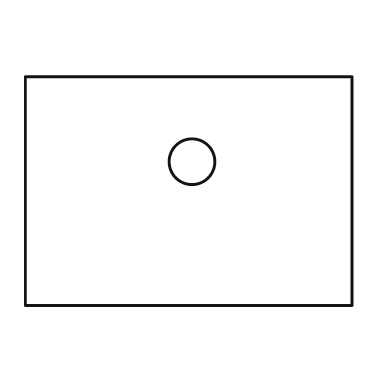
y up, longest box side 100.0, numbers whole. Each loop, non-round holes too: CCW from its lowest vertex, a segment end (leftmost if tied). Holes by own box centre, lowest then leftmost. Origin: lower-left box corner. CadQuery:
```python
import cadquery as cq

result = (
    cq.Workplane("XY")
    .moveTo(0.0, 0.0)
    .lineTo(100.0, 0.0)
    .lineTo(100.0, 70.0)
    .lineTo(0.0, 70.0)
    .close()
    .moveTo(51.0, 44.0)
    .circle(7.0)
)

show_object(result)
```